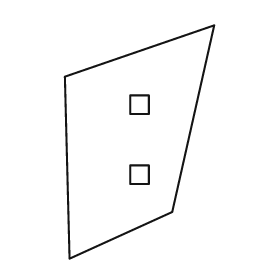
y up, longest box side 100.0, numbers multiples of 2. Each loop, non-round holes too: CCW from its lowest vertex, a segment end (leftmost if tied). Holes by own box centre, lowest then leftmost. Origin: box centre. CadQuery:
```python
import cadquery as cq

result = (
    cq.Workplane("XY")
    .moveTo(-30.0, -50.0)
    .lineTo(14.0, -30.0)
    .lineTo(32.0, 50.0)
    .lineTo(-32.0, 28.0)
    .close()
    .moveTo(-4.0, -18.0)
    .lineTo(4.0, -18.0)
    .lineTo(4.0, -10.0)
    .lineTo(-4.0, -10.0)
    .close()
    .moveTo(-4.0, 12.0)
    .lineTo(4.0, 12.0)
    .lineTo(4.0, 20.0)
    .lineTo(-4.0, 20.0)
    .close()
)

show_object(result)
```